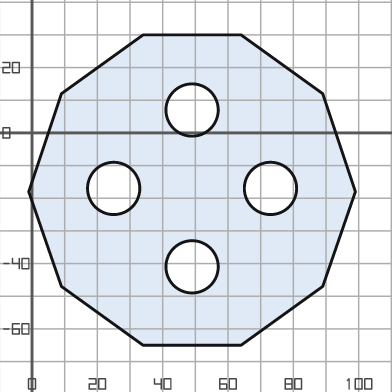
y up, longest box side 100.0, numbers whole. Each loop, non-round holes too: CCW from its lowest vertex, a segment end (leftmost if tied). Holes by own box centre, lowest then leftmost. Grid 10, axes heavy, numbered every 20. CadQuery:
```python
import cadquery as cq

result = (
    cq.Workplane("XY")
    .moveTo(34.0, -65.0)
    .lineTo(64.0, -65.0)
    .lineTo(89.0, -47.0)
    .lineTo(99.0, -18.0)
    .lineTo(89.0, 12.0)
    .lineTo(64.0, 30.0)
    .lineTo(34.0, 30.0)
    .lineTo(9.0, 12.0)
    .lineTo(-1.0, -18.0)
    .lineTo(9.0, -47.0)
    .close()
    .moveTo(49.0, -41.0)
    .circle(8.0)
    .moveTo(25.0, -17.0)
    .circle(8.0)
    .moveTo(73.0, -17.0)
    .circle(8.0)
    .moveTo(49.0, 7.0)
    .circle(8.0)
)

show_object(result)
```